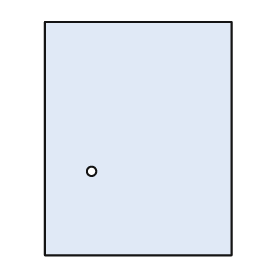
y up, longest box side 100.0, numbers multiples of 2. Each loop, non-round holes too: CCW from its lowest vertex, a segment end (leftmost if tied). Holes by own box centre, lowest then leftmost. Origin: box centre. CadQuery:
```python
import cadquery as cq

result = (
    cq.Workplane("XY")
    .moveTo(-40.0, -50.0)
    .lineTo(40.0, -50.0)
    .lineTo(40.0, 50.0)
    .lineTo(-40.0, 50.0)
    .close()
    .moveTo(-20.0, -14.0)
    .circle(2.0)
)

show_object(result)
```